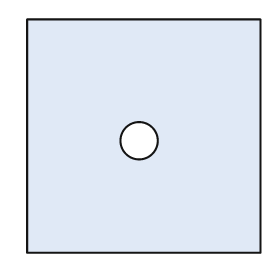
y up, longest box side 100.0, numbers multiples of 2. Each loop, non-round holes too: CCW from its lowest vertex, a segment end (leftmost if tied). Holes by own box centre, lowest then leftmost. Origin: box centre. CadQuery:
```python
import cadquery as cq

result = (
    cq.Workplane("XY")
    .moveTo(-50.0, -50.0)
    .lineTo(50.0, -50.0)
    .lineTo(50.0, 50.0)
    .lineTo(-50.0, 50.0)
    .close()
    .moveTo(-2.0, -2.0)
    .circle(8.0)
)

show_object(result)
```